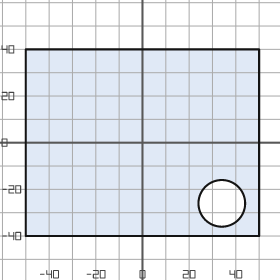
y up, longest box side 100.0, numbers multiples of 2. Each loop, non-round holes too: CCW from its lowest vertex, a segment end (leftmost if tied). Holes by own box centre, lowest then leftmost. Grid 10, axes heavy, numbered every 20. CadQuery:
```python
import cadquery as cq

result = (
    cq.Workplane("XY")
    .moveTo(-50.0, -40.0)
    .lineTo(50.0, -40.0)
    .lineTo(50.0, 40.0)
    .lineTo(-50.0, 40.0)
    .close()
    .moveTo(34.0, -26.0)
    .circle(10.0)
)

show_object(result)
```